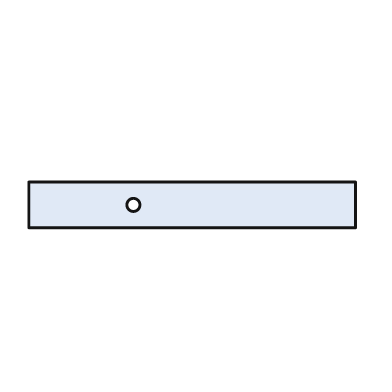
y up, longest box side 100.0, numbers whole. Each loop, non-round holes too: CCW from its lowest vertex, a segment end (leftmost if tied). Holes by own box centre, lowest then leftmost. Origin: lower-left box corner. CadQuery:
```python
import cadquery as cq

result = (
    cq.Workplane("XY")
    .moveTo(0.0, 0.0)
    .lineTo(100.0, 0.0)
    .lineTo(100.0, 14.0)
    .lineTo(0.0, 14.0)
    .close()
    .moveTo(32.0, 7.0)
    .circle(2.0)
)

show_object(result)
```